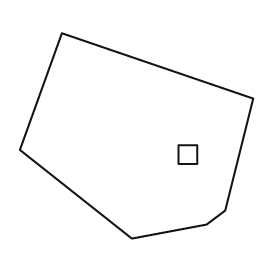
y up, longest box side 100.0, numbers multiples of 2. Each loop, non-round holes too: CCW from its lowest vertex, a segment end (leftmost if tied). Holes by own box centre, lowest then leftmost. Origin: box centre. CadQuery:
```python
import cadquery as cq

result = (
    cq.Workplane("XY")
    .moveTo(-2.0, -44.0)
    .lineTo(30.0, -38.0)
    .lineTo(38.0, -32.0)
    .lineTo(50.0, 16.0)
    .lineTo(-32.0, 44.0)
    .lineTo(-50.0, -6.0)
    .close()
    .moveTo(18.0, -12.0)
    .lineTo(26.0, -12.0)
    .lineTo(26.0, -4.0)
    .lineTo(18.0, -4.0)
    .close()
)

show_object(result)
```